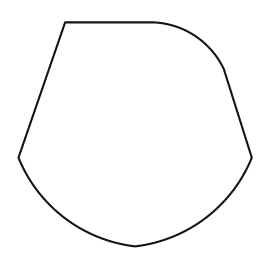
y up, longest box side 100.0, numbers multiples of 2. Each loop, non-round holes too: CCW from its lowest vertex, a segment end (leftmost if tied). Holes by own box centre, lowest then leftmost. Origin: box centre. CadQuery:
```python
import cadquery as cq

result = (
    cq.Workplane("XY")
    .moveTo(0.0, -48.0)
    .threePointArc((30.0, -36.0), (50.0, -10.0))
    .lineTo(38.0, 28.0)
    .threePointArc((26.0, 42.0), (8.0, 48.0))
    .lineTo(-30.0, 48.0)
    .lineTo(-50.0, -10.0)
    .threePointArc((-30.0, -36.0), (0.0, -48.0))
    .close()
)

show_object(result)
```